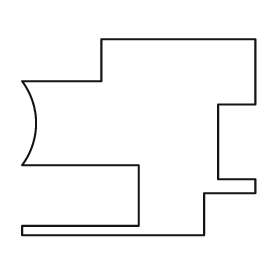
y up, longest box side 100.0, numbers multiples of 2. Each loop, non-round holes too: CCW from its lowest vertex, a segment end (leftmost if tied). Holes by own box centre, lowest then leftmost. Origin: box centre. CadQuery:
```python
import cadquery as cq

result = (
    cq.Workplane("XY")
    .moveTo(-50.0, -42.0)
    .lineTo(28.0, -42.0)
    .lineTo(28.0, -24.0)
    .lineTo(50.0, -24.0)
    .lineTo(50.0, -18.0)
    .lineTo(34.0, -18.0)
    .lineTo(34.0, 14.0)
    .lineTo(50.0, 14.0)
    .lineTo(50.0, 42.0)
    .lineTo(-16.0, 42.0)
    .lineTo(-16.0, 24.0)
    .lineTo(-50.0, 24.0)
    .threePointArc((-44.0, 6.0), (-50.0, -12.0))
    .lineTo(0.0, -12.0)
    .lineTo(0.0, -38.0)
    .lineTo(-50.0, -38.0)
    .close()
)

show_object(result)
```